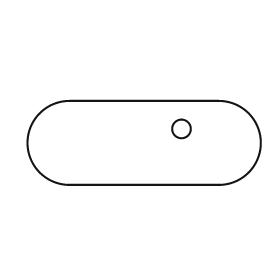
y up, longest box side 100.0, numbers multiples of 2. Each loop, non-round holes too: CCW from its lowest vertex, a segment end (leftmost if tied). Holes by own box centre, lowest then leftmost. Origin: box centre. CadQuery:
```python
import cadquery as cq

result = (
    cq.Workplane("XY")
    .moveTo(-32.0, -18.0)
    .lineTo(32.0, -18.0)
    .threePointArc((50.0, 0.0), (32.0, 18.0))
    .lineTo(-32.0, 18.0)
    .threePointArc((-50.0, 0.0), (-32.0, -18.0))
    .close()
    .moveTo(16.0, 6.0)
    .circle(4.0)
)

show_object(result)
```